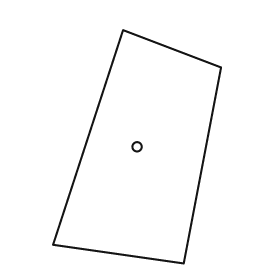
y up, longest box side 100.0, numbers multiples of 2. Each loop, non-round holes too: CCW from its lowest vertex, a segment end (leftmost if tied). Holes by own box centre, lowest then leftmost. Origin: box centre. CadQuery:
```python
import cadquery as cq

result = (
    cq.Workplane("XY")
    .moveTo(20.0, -50.0)
    .lineTo(36.0, 34.0)
    .lineTo(-6.0, 50.0)
    .lineTo(-36.0, -42.0)
    .close()
    .moveTo(0.0, 0.0)
    .circle(2.0)
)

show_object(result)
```